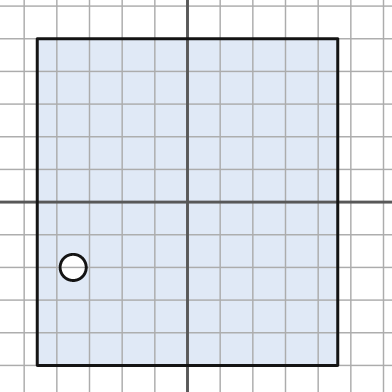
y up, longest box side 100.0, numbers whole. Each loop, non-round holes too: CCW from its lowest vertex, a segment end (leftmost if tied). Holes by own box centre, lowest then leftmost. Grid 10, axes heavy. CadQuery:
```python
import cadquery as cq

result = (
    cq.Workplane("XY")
    .moveTo(-46.0, -50.0)
    .lineTo(46.0, -50.0)
    .lineTo(46.0, 50.0)
    .lineTo(-46.0, 50.0)
    .close()
    .moveTo(-35.0, -20.0)
    .circle(4.0)
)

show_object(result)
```